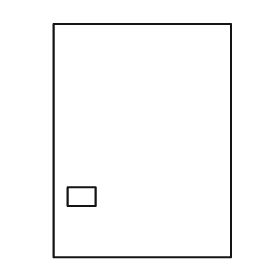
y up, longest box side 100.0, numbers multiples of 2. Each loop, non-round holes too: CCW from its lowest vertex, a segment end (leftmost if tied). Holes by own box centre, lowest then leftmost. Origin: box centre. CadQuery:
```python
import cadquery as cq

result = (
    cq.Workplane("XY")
    .moveTo(-38.0, -50.0)
    .lineTo(38.0, -50.0)
    .lineTo(38.0, 50.0)
    .lineTo(-38.0, 50.0)
    .close()
    .moveTo(-32.0, -28.0)
    .lineTo(-20.0, -28.0)
    .lineTo(-20.0, -20.0)
    .lineTo(-32.0, -20.0)
    .close()
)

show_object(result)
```